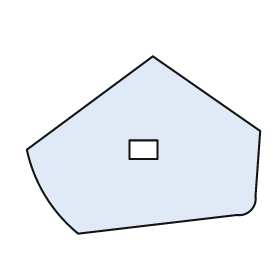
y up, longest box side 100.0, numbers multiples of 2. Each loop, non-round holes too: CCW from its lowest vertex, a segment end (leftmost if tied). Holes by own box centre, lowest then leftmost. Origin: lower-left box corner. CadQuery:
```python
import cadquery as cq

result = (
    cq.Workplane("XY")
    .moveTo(22.0, 0.0)
    .lineTo(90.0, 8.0)
    .threePointArc((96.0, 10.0), (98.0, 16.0))
    .lineTo(100.0, 44.0)
    .lineTo(54.0, 76.0)
    .lineTo(0.0, 36.0)
    .threePointArc((8.0, 16.0), (22.0, 0.0))
    .close()
    .moveTo(44.0, 32.0)
    .lineTo(56.0, 32.0)
    .lineTo(56.0, 40.0)
    .lineTo(44.0, 40.0)
    .close()
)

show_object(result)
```